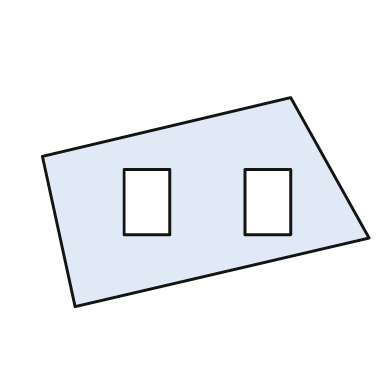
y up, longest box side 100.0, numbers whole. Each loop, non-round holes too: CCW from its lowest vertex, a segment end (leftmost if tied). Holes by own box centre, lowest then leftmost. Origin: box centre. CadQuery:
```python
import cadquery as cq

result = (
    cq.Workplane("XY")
    .moveTo(-40.0, -32.0)
    .lineTo(50.0, -11.0)
    .lineTo(26.0, 32.0)
    .lineTo(-50.0, 14.0)
    .close()
    .moveTo(-25.0, -10.0)
    .lineTo(-11.0, -10.0)
    .lineTo(-11.0, 10.0)
    .lineTo(-25.0, 10.0)
    .close()
    .moveTo(12.0, -10.0)
    .lineTo(26.0, -10.0)
    .lineTo(26.0, 10.0)
    .lineTo(12.0, 10.0)
    .close()
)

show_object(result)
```